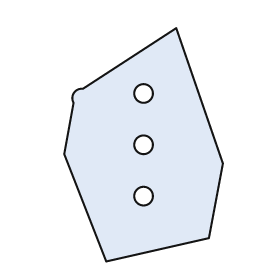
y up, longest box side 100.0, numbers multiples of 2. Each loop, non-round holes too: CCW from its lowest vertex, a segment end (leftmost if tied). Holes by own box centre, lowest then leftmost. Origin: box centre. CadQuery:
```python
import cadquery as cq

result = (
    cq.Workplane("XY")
    .moveTo(-16.0, -50.0)
    .lineTo(28.0, -40.0)
    .lineTo(34.0, -8.0)
    .lineTo(14.0, 50.0)
    .lineTo(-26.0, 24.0)
    .threePointArc((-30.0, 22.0), (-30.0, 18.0))
    .lineTo(-34.0, -4.0)
    .close()
    .moveTo(0.0, -22.0)
    .circle(4.0)
    .moveTo(0.0, 0.0)
    .circle(4.0)
    .moveTo(0.0, 22.0)
    .circle(4.0)
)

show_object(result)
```